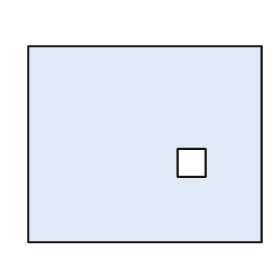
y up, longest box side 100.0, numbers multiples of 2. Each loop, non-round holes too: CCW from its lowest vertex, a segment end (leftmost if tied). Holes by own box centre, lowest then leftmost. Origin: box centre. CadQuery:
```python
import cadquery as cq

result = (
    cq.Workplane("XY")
    .moveTo(-50.0, -42.0)
    .lineTo(50.0, -42.0)
    .lineTo(50.0, 42.0)
    .lineTo(-50.0, 42.0)
    .close()
    .moveTo(14.0, -14.0)
    .lineTo(26.0, -14.0)
    .lineTo(26.0, -2.0)
    .lineTo(14.0, -2.0)
    .close()
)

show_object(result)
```